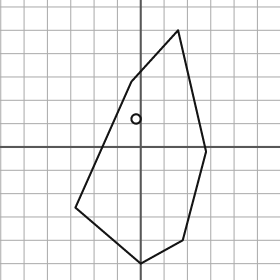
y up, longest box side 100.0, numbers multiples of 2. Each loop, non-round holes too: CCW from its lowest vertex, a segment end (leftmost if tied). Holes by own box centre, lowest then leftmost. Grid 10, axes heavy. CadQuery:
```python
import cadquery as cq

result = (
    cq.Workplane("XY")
    .moveTo(0.0, -50.0)
    .lineTo(18.0, -40.0)
    .lineTo(28.0, -2.0)
    .lineTo(16.0, 50.0)
    .lineTo(-4.0, 28.0)
    .lineTo(-28.0, -26.0)
    .close()
    .moveTo(-2.0, 12.0)
    .circle(2.0)
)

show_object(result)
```